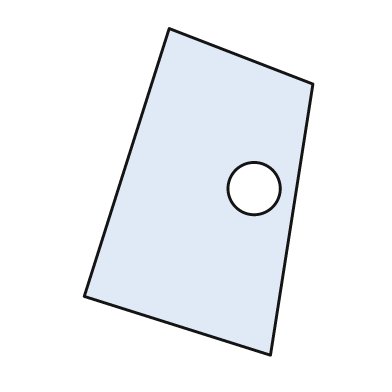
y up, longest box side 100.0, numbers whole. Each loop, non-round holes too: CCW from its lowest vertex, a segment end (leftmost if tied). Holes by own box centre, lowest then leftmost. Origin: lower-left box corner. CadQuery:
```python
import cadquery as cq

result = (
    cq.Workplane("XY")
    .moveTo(57.0, 0.0)
    .lineTo(70.0, 83.0)
    .lineTo(26.0, 100.0)
    .lineTo(0.0, 18.0)
    .close()
    .moveTo(52.0, 51.0)
    .circle(8.0)
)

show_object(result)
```